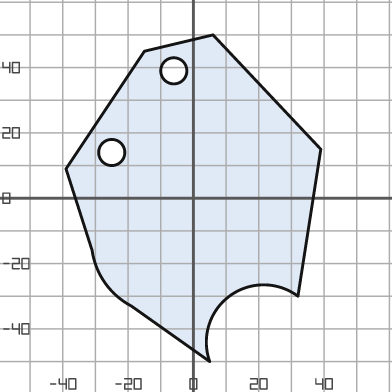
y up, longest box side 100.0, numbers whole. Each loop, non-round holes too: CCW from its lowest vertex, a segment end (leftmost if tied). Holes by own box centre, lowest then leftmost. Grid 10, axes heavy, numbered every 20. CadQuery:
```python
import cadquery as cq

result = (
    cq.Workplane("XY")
    .moveTo(5.0, -50.0)
    .threePointArc((11.0, -30.0), (32.0, -30.0))
    .lineTo(39.0, 15.0)
    .lineTo(6.0, 50.0)
    .lineTo(-15.0, 45.0)
    .lineTo(-39.0, 9.0)
    .lineTo(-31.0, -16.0)
    .threePointArc((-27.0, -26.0), (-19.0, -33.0))
    .close()
    .moveTo(-25.0, 14.0)
    .circle(4.0)
    .moveTo(-6.0, 39.0)
    .circle(4.0)
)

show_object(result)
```